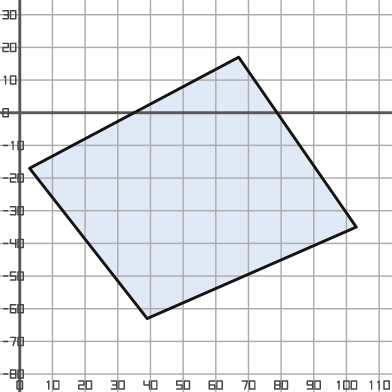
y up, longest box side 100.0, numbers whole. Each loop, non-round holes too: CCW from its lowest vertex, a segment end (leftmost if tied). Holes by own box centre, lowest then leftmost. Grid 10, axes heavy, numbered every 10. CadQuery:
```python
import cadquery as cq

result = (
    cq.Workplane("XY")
    .moveTo(39.0, -63.0)
    .lineTo(103.0, -35.0)
    .lineTo(67.0, 17.0)
    .lineTo(3.0, -17.0)
    .close()
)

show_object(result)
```